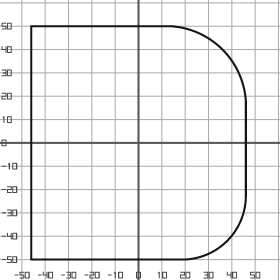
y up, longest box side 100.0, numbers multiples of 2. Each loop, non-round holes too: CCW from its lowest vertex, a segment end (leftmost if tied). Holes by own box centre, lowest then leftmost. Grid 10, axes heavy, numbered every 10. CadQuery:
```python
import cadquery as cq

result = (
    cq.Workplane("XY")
    .moveTo(-46.0, -50.0)
    .lineTo(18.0, -50.0)
    .threePointArc((38.0, -42.0), (46.0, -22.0))
    .lineTo(46.0, 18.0)
    .threePointArc((36.0, 40.0), (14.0, 50.0))
    .lineTo(-46.0, 50.0)
    .close()
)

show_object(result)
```